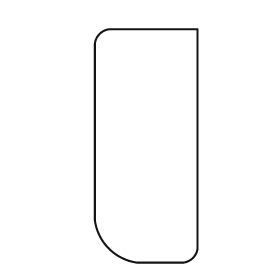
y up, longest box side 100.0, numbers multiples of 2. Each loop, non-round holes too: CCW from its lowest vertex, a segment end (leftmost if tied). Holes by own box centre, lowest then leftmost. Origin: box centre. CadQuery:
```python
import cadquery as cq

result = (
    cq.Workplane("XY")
    .moveTo(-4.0, -50.0)
    .lineTo(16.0, -50.0)
    .threePointArc((20.0, -48.0), (22.0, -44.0))
    .lineTo(22.0, 50.0)
    .lineTo(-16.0, 50.0)
    .threePointArc((-20.0, 48.0), (-22.0, 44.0))
    .lineTo(-22.0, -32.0)
    .threePointArc((-16.0, -44.0), (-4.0, -50.0))
    .close()
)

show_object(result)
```